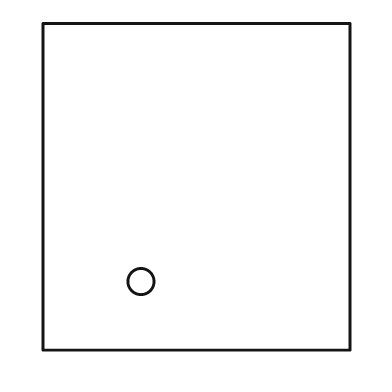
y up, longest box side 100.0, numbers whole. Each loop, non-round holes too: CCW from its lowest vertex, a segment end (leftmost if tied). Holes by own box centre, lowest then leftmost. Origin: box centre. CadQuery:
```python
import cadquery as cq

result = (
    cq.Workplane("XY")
    .moveTo(-47.0, -50.0)
    .lineTo(47.0, -50.0)
    .lineTo(47.0, 50.0)
    .lineTo(-47.0, 50.0)
    .close()
    .moveTo(-17.0, -29.0)
    .circle(4.0)
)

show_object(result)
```